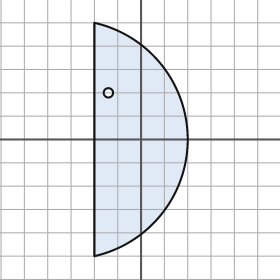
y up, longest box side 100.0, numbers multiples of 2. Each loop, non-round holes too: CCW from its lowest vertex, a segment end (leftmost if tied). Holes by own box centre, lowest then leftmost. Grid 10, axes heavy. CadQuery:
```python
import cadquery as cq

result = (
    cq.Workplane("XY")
    .moveTo(-20.0, -50.0)
    .threePointArc((20.0, 0.0), (-20.0, 50.0))
    .close()
    .moveTo(-14.0, 20.0)
    .circle(2.0)
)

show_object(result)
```